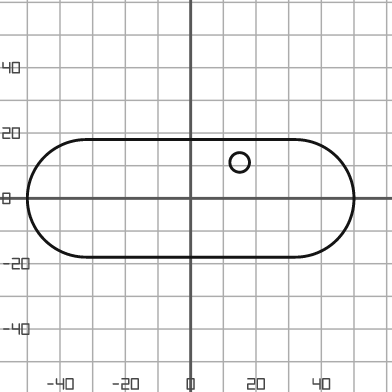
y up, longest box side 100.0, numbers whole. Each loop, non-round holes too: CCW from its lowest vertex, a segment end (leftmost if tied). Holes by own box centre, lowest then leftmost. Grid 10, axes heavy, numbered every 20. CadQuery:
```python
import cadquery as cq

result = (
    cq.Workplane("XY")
    .moveTo(-32.0, -18.0)
    .lineTo(32.0, -18.0)
    .threePointArc((50.0, 0.0), (32.0, 18.0))
    .lineTo(-32.0, 18.0)
    .threePointArc((-50.0, 0.0), (-32.0, -18.0))
    .close()
    .moveTo(15.0, 11.0)
    .circle(3.0)
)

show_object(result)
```